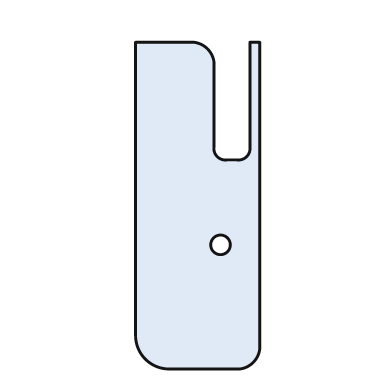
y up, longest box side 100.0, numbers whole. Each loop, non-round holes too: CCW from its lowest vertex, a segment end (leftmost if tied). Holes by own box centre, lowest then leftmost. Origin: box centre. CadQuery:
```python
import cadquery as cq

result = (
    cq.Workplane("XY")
    .moveTo(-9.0, -50.0)
    .lineTo(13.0, -50.0)
    .threePointArc((17.0, -48.0), (19.0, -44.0))
    .lineTo(19.0, 50.0)
    .lineTo(16.0, 50.0)
    .lineTo(16.0, 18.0)
    .threePointArc((15.0, 15.0), (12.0, 14.0))
    .lineTo(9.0, 14.0)
    .threePointArc((6.0, 15.0), (5.0, 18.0))
    .lineTo(5.0, 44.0)
    .threePointArc((3.0, 48.0), (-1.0, 50.0))
    .lineTo(-19.0, 50.0)
    .lineTo(-19.0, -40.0)
    .threePointArc((-16.0, -47.0), (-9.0, -50.0))
    .close()
    .moveTo(7.0, -12.0)
    .circle(3.0)
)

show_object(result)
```